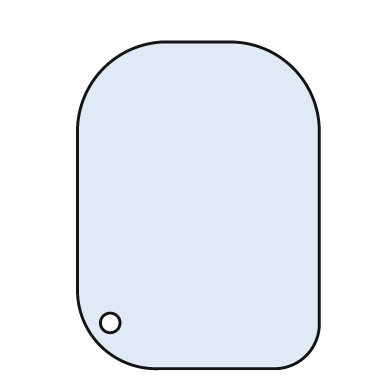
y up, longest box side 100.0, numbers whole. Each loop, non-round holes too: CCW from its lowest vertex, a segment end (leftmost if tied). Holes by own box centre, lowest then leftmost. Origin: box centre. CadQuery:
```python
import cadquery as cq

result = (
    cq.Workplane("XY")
    .moveTo(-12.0, -50.0)
    .lineTo(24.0, -50.0)
    .threePointArc((33.0, -46.0), (37.0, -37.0))
    .lineTo(37.0, 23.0)
    .threePointArc((29.0, 42.0), (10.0, 50.0))
    .lineTo(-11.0, 50.0)
    .threePointArc((-29.0, 42.0), (-37.0, 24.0))
    .lineTo(-37.0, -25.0)
    .threePointArc((-30.0, -43.0), (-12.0, -50.0))
    .close()
    .moveTo(-27.0, -36.0)
    .circle(3.0)
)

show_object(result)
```